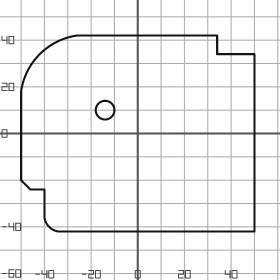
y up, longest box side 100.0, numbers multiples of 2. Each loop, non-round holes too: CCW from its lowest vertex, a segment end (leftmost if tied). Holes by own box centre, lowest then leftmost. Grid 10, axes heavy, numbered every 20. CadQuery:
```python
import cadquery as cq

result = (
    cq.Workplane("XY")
    .moveTo(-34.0, -42.0)
    .lineTo(50.0, -42.0)
    .lineTo(50.0, 34.0)
    .lineTo(34.0, 34.0)
    .lineTo(34.0, 42.0)
    .lineTo(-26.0, 42.0)
    .threePointArc((-42.0, 34.0), (-50.0, 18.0))
    .lineTo(-50.0, -20.0)
    .lineTo(-46.0, -24.0)
    .lineTo(-40.0, -24.0)
    .lineTo(-40.0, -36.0)
    .threePointArc((-38.0, -40.0), (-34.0, -42.0))
    .close()
    .moveTo(-14.0, 10.0)
    .circle(4.0)
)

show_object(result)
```